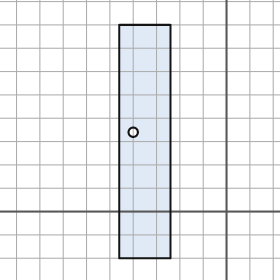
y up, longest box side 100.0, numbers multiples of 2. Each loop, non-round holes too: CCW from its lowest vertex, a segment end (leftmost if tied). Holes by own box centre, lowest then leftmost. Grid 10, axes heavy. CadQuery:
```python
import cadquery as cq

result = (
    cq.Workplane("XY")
    .moveTo(-46.0, -20.0)
    .lineTo(-24.0, -20.0)
    .lineTo(-24.0, 80.0)
    .lineTo(-46.0, 80.0)
    .close()
    .moveTo(-40.0, 34.0)
    .circle(2.0)
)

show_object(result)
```